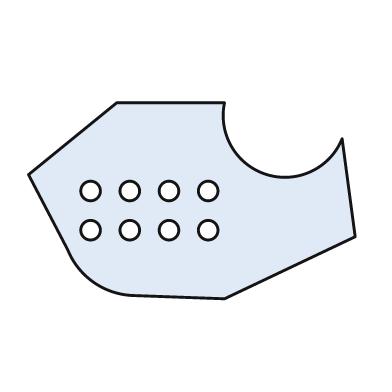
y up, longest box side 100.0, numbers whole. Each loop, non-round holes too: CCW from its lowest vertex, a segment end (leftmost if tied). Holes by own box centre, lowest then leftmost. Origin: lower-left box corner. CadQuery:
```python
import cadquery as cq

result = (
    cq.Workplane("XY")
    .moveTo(60.0, 0.0)
    .lineTo(100.0, 19.0)
    .lineTo(96.0, 49.0)
    .threePointArc((73.0, 38.0), (60.0, 60.0))
    .lineTo(27.0, 60.0)
    .lineTo(0.0, 38.0)
    .lineTo(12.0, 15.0)
    .threePointArc((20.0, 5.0), (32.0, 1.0))
    .close()
    .moveTo(19.0, 21.0)
    .circle(3.0)
    .moveTo(31.0, 21.0)
    .circle(3.0)
    .moveTo(43.0, 21.0)
    .circle(3.0)
    .moveTo(55.0, 21.0)
    .circle(3.0)
    .moveTo(19.0, 33.0)
    .circle(3.0)
    .moveTo(31.0, 33.0)
    .circle(3.0)
    .moveTo(43.0, 33.0)
    .circle(3.0)
    .moveTo(55.0, 33.0)
    .circle(3.0)
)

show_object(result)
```